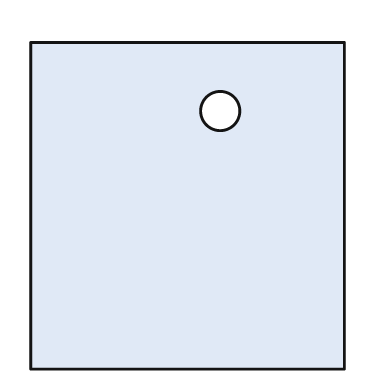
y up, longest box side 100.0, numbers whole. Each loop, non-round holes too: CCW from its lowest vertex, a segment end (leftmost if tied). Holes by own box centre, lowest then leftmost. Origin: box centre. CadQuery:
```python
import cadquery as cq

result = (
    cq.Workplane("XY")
    .moveTo(-48.0, -50.0)
    .lineTo(48.0, -50.0)
    .lineTo(48.0, 50.0)
    .lineTo(-48.0, 50.0)
    .close()
    .moveTo(10.0, 29.0)
    .circle(6.0)
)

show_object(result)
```